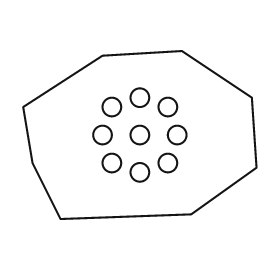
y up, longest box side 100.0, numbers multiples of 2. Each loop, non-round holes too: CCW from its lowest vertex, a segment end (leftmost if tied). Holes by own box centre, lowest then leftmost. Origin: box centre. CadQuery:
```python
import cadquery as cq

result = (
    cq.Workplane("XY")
    .moveTo(-34.0, -36.0)
    .lineTo(22.0, -34.0)
    .lineTo(50.0, -14.0)
    .lineTo(48.0, 16.0)
    .lineTo(18.0, 36.0)
    .lineTo(-16.0, 34.0)
    .lineTo(-50.0, 12.0)
    .lineTo(-46.0, -12.0)
    .close()
    .moveTo(0.0, -16.0)
    .circle(4.0)
    .moveTo(-12.0, -12.0)
    .circle(4.0)
    .moveTo(12.0, -12.0)
    .circle(4.0)
    .moveTo(-16.0, 0.0)
    .circle(4.0)
    .moveTo(0.0, 0.0)
    .circle(4.0)
    .moveTo(16.0, 0.0)
    .circle(4.0)
    .moveTo(-12.0, 12.0)
    .circle(4.0)
    .moveTo(12.0, 12.0)
    .circle(4.0)
    .moveTo(0.0, 16.0)
    .circle(4.0)
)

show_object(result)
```